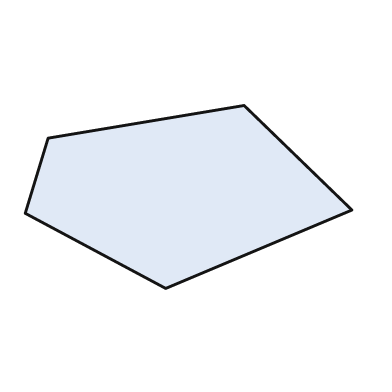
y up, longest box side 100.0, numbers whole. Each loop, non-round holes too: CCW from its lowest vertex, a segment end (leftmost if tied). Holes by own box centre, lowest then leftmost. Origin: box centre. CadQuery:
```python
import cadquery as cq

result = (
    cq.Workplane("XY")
    .moveTo(-7.0, -28.0)
    .lineTo(50.0, -4.0)
    .lineTo(17.0, 28.0)
    .lineTo(-43.0, 18.0)
    .lineTo(-50.0, -5.0)
    .close()
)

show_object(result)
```